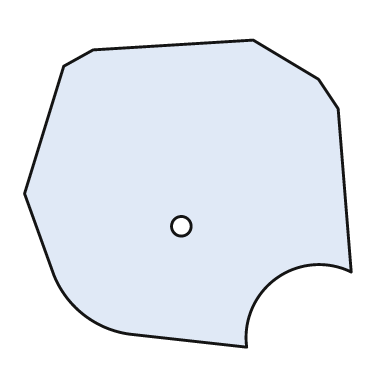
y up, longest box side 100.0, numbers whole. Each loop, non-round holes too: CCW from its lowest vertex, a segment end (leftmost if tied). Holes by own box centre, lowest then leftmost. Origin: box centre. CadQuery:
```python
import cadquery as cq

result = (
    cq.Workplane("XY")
    .moveTo(18.0, -47.0)
    .threePointArc((27.0, -26.0), (50.0, -24.0))
    .lineTo(46.0, 26.0)
    .lineTo(40.0, 35.0)
    .lineTo(20.0, 47.0)
    .lineTo(-29.0, 44.0)
    .lineTo(-38.0, 39.0)
    .lineTo(-50.0, 0.0)
    .lineTo(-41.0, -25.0)
    .threePointArc((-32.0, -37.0), (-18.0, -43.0))
    .close()
    .moveTo(-2.0, -10.0)
    .circle(3.0)
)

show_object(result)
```